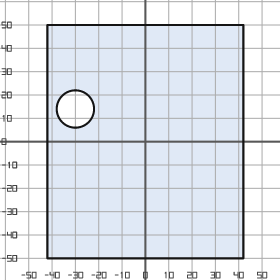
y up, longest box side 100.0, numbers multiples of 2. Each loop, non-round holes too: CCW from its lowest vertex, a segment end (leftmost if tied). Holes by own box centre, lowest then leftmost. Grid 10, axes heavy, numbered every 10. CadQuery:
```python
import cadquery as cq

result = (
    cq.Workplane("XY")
    .moveTo(-42.0, -50.0)
    .lineTo(42.0, -50.0)
    .lineTo(42.0, 50.0)
    .lineTo(-42.0, 50.0)
    .close()
    .moveTo(-30.0, 14.0)
    .circle(8.0)
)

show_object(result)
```